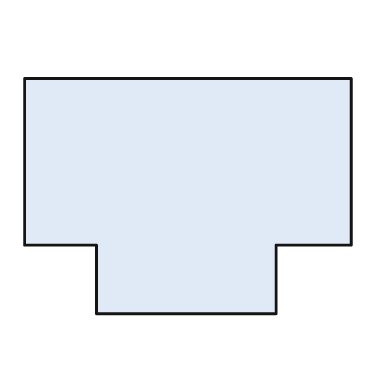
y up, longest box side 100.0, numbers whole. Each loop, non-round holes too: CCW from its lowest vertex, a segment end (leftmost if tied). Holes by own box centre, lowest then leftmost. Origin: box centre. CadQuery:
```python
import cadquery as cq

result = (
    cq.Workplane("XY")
    .moveTo(-28.0, -36.0)
    .lineTo(27.0, -36.0)
    .lineTo(27.0, -15.0)
    .lineTo(50.0, -15.0)
    .lineTo(50.0, 36.0)
    .lineTo(-50.0, 36.0)
    .lineTo(-50.0, -15.0)
    .lineTo(-28.0, -15.0)
    .close()
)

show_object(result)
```